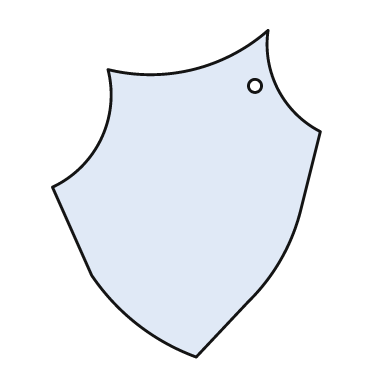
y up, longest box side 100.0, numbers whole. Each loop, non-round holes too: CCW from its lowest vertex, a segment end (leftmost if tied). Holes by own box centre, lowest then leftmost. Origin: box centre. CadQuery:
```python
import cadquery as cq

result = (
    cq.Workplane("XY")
    .moveTo(3.0, -50.0)
    .lineTo(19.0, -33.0)
    .threePointArc((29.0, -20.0), (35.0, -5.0))
    .lineTo(41.0, 19.0)
    .threePointArc((28.0, 32.0), (25.0, 50.0))
    .threePointArc((2.0, 38.0), (-24.0, 38.0))
    .threePointArc((-26.0, 17.0), (-41.0, 2.0))
    .lineTo(-29.0, -25.0)
    .threePointArc((-15.0, -40.0), (3.0, -50.0))
    .close()
    .moveTo(21.0, 33.0)
    .circle(2.0)
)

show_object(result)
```